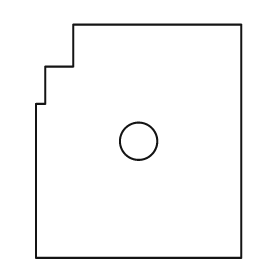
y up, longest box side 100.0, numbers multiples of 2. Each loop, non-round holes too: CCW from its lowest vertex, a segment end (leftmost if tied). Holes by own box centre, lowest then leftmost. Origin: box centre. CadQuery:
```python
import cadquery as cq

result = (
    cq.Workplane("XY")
    .moveTo(-44.0, -50.0)
    .lineTo(44.0, -50.0)
    .lineTo(44.0, 50.0)
    .lineTo(-28.0, 50.0)
    .lineTo(-28.0, 32.0)
    .lineTo(-40.0, 32.0)
    .lineTo(-40.0, 16.0)
    .lineTo(-44.0, 16.0)
    .close()
    .moveTo(0.0, 0.0)
    .circle(8.0)
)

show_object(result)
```